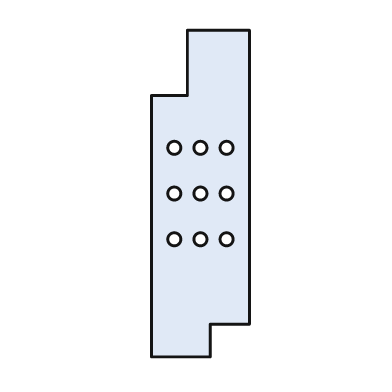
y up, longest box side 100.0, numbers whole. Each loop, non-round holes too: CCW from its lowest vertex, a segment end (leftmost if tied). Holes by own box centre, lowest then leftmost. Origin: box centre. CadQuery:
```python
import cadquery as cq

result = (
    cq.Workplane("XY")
    .moveTo(-15.0, -50.0)
    .lineTo(3.0, -50.0)
    .lineTo(3.0, -40.0)
    .lineTo(15.0, -40.0)
    .lineTo(15.0, 50.0)
    .lineTo(-4.0, 50.0)
    .lineTo(-4.0, 30.0)
    .lineTo(-15.0, 30.0)
    .close()
    .moveTo(-8.0, -14.0)
    .circle(2.0)
    .moveTo(0.0, -14.0)
    .circle(2.0)
    .moveTo(8.0, -14.0)
    .circle(2.0)
    .moveTo(-8.0, 0.0)
    .circle(2.0)
    .moveTo(0.0, 0.0)
    .circle(2.0)
    .moveTo(8.0, 0.0)
    .circle(2.0)
    .moveTo(-8.0, 14.0)
    .circle(2.0)
    .moveTo(0.0, 14.0)
    .circle(2.0)
    .moveTo(8.0, 14.0)
    .circle(2.0)
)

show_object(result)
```